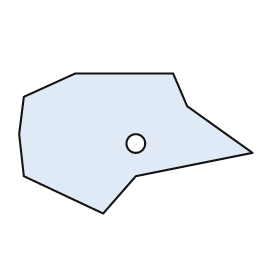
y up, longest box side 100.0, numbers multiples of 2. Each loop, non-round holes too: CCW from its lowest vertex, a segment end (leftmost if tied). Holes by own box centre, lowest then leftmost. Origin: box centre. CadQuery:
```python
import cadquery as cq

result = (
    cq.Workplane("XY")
    .moveTo(-14.0, -30.0)
    .lineTo(0.0, -14.0)
    .lineTo(50.0, -4.0)
    .lineTo(22.0, 16.0)
    .lineTo(16.0, 30.0)
    .lineTo(-26.0, 30.0)
    .lineTo(-48.0, 20.0)
    .lineTo(-50.0, 4.0)
    .lineTo(-48.0, -14.0)
    .close()
    .moveTo(0.0, 0.0)
    .circle(4.0)
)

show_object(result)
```